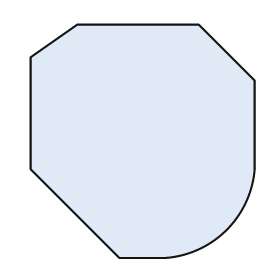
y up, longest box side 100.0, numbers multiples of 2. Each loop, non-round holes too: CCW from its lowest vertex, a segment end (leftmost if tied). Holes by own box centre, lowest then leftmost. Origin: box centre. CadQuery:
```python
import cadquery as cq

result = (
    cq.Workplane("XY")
    .moveTo(-10.0, -50.0)
    .lineTo(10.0, -50.0)
    .threePointArc((36.0, -38.0), (48.0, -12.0))
    .lineTo(48.0, 26.0)
    .lineTo(24.0, 50.0)
    .lineTo(-28.0, 50.0)
    .lineTo(-48.0, 36.0)
    .lineTo(-48.0, -12.0)
    .close()
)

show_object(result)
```